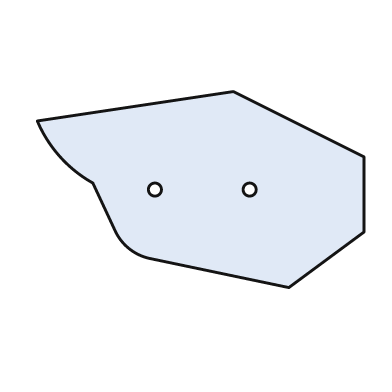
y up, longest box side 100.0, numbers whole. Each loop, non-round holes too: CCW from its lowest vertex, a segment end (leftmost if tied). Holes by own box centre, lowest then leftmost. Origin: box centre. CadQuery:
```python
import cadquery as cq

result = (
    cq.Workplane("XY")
    .moveTo(27.0, -30.0)
    .lineTo(50.0, -13.0)
    .lineTo(50.0, 10.0)
    .lineTo(10.0, 30.0)
    .lineTo(-50.0, 21.0)
    .threePointArc((-43.0, 10.0), (-33.0, 2.0))
    .lineTo(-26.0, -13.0)
    .threePointArc((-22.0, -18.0), (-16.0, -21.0))
    .close()
    .moveTo(-14.0, 0.0)
    .circle(2.0)
    .moveTo(15.0, 0.0)
    .circle(2.0)
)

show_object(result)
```